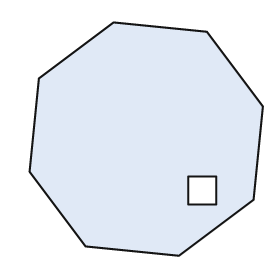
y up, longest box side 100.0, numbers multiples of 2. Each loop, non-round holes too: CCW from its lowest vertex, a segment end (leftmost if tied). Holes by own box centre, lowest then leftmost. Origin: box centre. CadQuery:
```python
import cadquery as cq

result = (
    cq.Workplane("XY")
    .moveTo(14.0, -50.0)
    .lineTo(46.0, -26.0)
    .lineTo(50.0, 14.0)
    .lineTo(26.0, 46.0)
    .lineTo(-14.0, 50.0)
    .lineTo(-46.0, 26.0)
    .lineTo(-50.0, -14.0)
    .lineTo(-26.0, -46.0)
    .close()
    .moveTo(18.0, -28.0)
    .lineTo(30.0, -28.0)
    .lineTo(30.0, -16.0)
    .lineTo(18.0, -16.0)
    .close()
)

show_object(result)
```